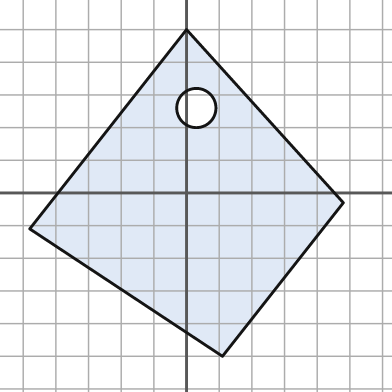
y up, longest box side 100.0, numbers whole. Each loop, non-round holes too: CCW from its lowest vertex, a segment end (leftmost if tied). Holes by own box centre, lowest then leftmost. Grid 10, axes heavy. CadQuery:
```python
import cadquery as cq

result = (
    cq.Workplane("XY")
    .moveTo(11.0, -50.0)
    .lineTo(48.0, -3.0)
    .lineTo(0.0, 50.0)
    .lineTo(-48.0, -11.0)
    .close()
    .moveTo(3.0, 26.0)
    .circle(6.0)
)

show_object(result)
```